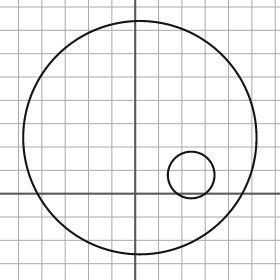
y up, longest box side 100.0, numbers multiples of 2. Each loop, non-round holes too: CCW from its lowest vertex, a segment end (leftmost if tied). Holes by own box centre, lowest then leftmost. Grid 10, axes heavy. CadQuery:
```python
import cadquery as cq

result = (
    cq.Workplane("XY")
    .moveTo(2.0, 24.0)
    .circle(50.0)
    .moveTo(24.0, 8.0)
    .circle(10.0)
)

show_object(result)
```